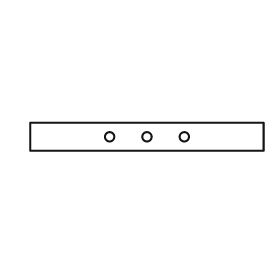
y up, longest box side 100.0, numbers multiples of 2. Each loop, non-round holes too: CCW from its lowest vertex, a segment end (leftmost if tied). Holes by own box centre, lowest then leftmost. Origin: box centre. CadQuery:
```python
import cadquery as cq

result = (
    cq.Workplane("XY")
    .moveTo(-50.0, -6.0)
    .lineTo(50.0, -6.0)
    .lineTo(50.0, 6.0)
    .lineTo(-50.0, 6.0)
    .close()
    .moveTo(-16.0, 0.0)
    .circle(2.0)
    .moveTo(0.0, 0.0)
    .circle(2.0)
    .moveTo(16.0, 0.0)
    .circle(2.0)
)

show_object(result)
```